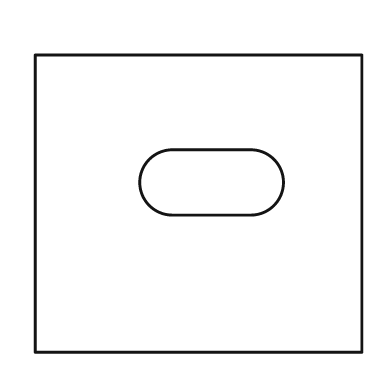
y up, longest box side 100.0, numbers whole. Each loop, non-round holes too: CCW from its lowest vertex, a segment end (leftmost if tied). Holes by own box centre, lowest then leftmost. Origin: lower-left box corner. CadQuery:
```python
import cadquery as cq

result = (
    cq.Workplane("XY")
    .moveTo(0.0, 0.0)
    .lineTo(100.0, 0.0)
    .lineTo(100.0, 91.0)
    .lineTo(0.0, 91.0)
    .close()
    .moveTo(42.0, 42.0)
    .lineTo(66.0, 42.0)
    .threePointArc((76.0, 52.0), (66.0, 62.0))
    .lineTo(42.0, 62.0)
    .threePointArc((32.0, 52.0), (42.0, 42.0))
    .close()
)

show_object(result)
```